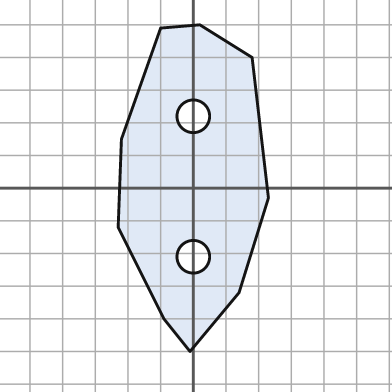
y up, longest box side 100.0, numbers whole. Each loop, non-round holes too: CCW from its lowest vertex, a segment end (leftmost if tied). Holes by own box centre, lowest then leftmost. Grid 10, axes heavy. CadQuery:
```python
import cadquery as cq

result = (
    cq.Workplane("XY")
    .moveTo(-1.0, -50.0)
    .lineTo(14.0, -32.0)
    .lineTo(23.0, -3.0)
    .lineTo(18.0, 40.0)
    .lineTo(2.0, 50.0)
    .lineTo(-10.0, 49.0)
    .lineTo(-22.0, 15.0)
    .lineTo(-23.0, -12.0)
    .lineTo(-9.0, -40.0)
    .close()
    .moveTo(0.0, -21.0)
    .circle(5.0)
    .moveTo(0.0, 22.0)
    .circle(5.0)
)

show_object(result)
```